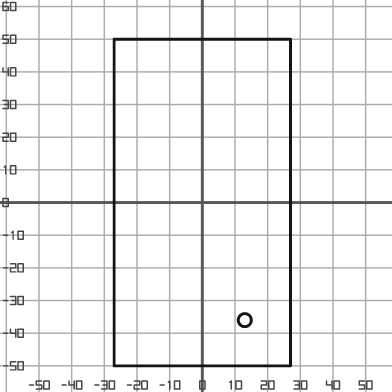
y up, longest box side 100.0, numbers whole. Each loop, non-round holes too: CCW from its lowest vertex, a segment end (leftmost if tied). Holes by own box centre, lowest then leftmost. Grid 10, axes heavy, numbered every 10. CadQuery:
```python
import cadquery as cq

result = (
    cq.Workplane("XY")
    .moveTo(-27.0, -50.0)
    .lineTo(27.0, -50.0)
    .lineTo(27.0, 50.0)
    .lineTo(-27.0, 50.0)
    .close()
    .moveTo(13.0, -36.0)
    .circle(2.0)
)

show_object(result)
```